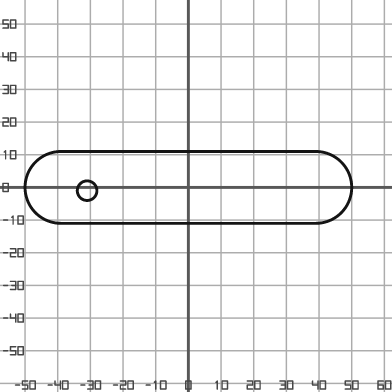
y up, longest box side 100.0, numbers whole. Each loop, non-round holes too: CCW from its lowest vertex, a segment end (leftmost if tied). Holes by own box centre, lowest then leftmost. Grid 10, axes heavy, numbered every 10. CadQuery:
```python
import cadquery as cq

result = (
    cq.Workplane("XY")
    .moveTo(-39.0, -11.0)
    .lineTo(39.0, -11.0)
    .threePointArc((50.0, 0.0), (39.0, 11.0))
    .lineTo(-39.0, 11.0)
    .threePointArc((-50.0, 0.0), (-39.0, -11.0))
    .close()
    .moveTo(-31.0, -1.0)
    .circle(3.0)
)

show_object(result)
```